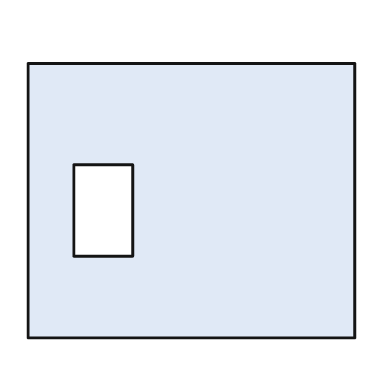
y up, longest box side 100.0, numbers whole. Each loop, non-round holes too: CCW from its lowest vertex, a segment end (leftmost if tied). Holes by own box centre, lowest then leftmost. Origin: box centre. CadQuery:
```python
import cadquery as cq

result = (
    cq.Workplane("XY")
    .moveTo(-50.0, -42.0)
    .lineTo(50.0, -42.0)
    .lineTo(50.0, 42.0)
    .lineTo(-50.0, 42.0)
    .close()
    .moveTo(-36.0, -17.0)
    .lineTo(-18.0, -17.0)
    .lineTo(-18.0, 11.0)
    .lineTo(-36.0, 11.0)
    .close()
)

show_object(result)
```